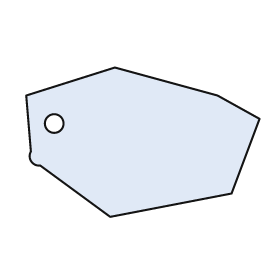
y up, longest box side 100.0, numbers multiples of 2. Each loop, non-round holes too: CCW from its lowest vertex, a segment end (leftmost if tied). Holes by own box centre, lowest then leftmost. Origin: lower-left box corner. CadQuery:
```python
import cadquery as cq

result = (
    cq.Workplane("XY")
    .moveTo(36.0, 0.0)
    .lineTo(88.0, 10.0)
    .lineTo(100.0, 42.0)
    .lineTo(82.0, 52.0)
    .lineTo(38.0, 64.0)
    .lineTo(0.0, 52.0)
    .lineTo(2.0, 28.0)
    .threePointArc((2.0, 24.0), (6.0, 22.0))
    .close()
    .moveTo(12.0, 40.0)
    .circle(4.0)
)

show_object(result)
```